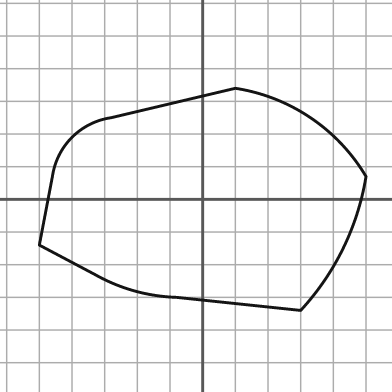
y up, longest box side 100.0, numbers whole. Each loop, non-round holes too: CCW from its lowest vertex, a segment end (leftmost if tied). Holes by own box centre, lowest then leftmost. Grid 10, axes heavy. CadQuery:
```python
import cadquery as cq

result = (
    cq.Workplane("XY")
    .moveTo(30.0, -34.0)
    .threePointArc((43.0, -15.0), (50.0, 7.0))
    .threePointArc((33.0, 25.0), (10.0, 34.0))
    .lineTo(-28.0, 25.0)
    .threePointArc((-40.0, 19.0), (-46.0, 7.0))
    .lineTo(-50.0, -14.0)
    .lineTo(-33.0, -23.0)
    .threePointArc((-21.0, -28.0), (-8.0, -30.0))
    .close()
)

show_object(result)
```